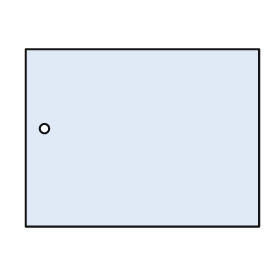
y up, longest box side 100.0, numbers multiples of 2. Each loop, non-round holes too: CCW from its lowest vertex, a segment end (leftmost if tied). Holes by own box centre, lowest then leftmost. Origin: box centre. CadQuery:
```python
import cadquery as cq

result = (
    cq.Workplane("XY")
    .moveTo(-50.0, -38.0)
    .lineTo(50.0, -38.0)
    .lineTo(50.0, 38.0)
    .lineTo(-50.0, 38.0)
    .close()
    .moveTo(-42.0, 4.0)
    .circle(2.0)
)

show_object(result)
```